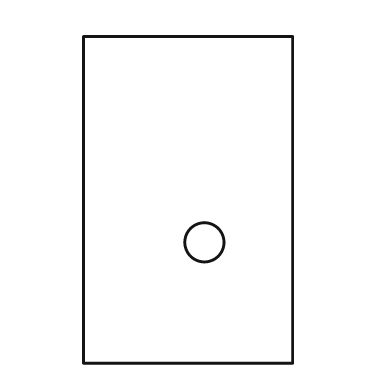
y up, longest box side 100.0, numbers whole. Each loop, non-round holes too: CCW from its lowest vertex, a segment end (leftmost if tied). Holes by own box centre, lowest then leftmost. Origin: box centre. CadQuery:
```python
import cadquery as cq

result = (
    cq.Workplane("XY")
    .moveTo(-32.0, -50.0)
    .lineTo(32.0, -50.0)
    .lineTo(32.0, 50.0)
    .lineTo(-32.0, 50.0)
    .close()
    .moveTo(5.0, -13.0)
    .circle(6.0)
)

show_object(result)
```